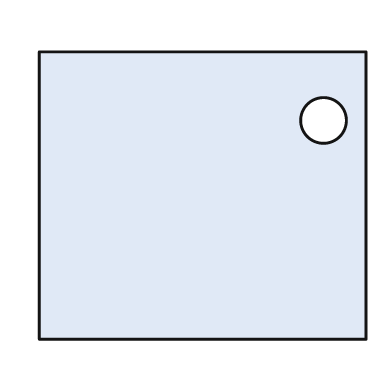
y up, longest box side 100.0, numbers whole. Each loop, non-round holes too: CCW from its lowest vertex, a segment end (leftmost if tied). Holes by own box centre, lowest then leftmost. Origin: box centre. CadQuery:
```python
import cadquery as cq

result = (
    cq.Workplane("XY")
    .moveTo(-50.0, -44.0)
    .lineTo(50.0, -44.0)
    .lineTo(50.0, 44.0)
    .lineTo(-50.0, 44.0)
    .close()
    .moveTo(37.0, 23.0)
    .circle(7.0)
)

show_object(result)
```